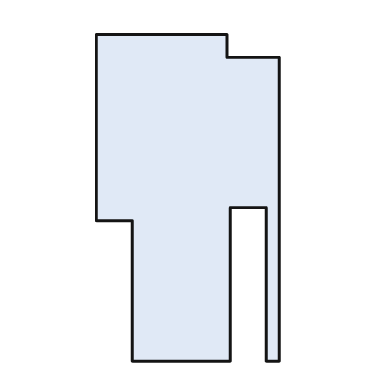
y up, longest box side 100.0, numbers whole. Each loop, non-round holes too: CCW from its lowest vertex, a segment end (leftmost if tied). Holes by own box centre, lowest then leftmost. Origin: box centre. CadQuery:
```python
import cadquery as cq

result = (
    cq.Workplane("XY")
    .moveTo(-17.0, -50.0)
    .lineTo(13.0, -50.0)
    .lineTo(13.0, -3.0)
    .lineTo(24.0, -3.0)
    .lineTo(24.0, -50.0)
    .lineTo(28.0, -50.0)
    .lineTo(28.0, 43.0)
    .lineTo(12.0, 43.0)
    .lineTo(12.0, 50.0)
    .lineTo(-28.0, 50.0)
    .lineTo(-28.0, -7.0)
    .lineTo(-17.0, -7.0)
    .close()
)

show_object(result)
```